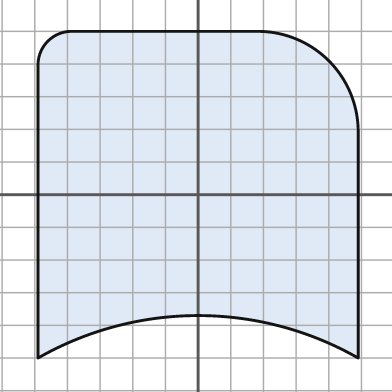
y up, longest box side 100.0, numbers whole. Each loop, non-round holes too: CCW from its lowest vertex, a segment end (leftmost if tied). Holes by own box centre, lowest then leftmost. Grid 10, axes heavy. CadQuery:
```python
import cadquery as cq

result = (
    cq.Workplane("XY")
    .moveTo(-49.0, -50.0)
    .threePointArc((0.0, -37.0), (49.0, -50.0))
    .lineTo(49.0, 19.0)
    .threePointArc((40.0, 41.0), (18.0, 50.0))
    .lineTo(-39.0, 50.0)
    .threePointArc((-46.0, 47.0), (-49.0, 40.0))
    .close()
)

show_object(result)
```